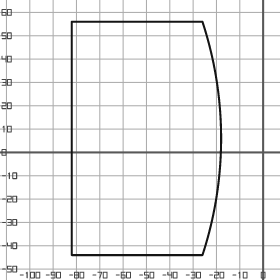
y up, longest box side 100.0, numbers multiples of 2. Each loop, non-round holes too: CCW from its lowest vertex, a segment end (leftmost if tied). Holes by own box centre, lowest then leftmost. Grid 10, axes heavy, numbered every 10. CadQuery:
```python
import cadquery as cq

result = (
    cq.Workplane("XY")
    .moveTo(-82.0, -44.0)
    .lineTo(-26.0, -44.0)
    .threePointArc((-18.0, 6.0), (-26.0, 56.0))
    .lineTo(-82.0, 56.0)
    .close()
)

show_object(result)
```